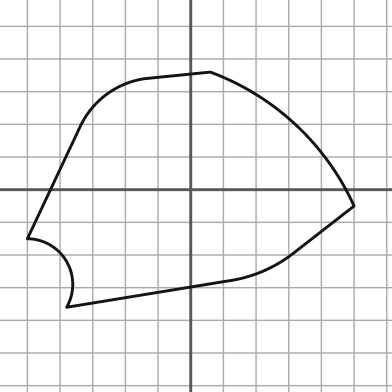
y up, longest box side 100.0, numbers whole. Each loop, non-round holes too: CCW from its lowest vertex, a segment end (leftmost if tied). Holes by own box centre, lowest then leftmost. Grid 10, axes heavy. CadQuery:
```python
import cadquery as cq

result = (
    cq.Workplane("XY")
    .moveTo(-38.0, -36.0)
    .lineTo(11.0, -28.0)
    .threePointArc((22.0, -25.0), (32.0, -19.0))
    .lineTo(50.0, -5.0)
    .threePointArc((32.0, 20.0), (6.0, 36.0))
    .lineTo(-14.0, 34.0)
    .threePointArc((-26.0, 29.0), (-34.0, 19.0))
    .lineTo(-50.0, -15.0)
    .threePointArc((-38.0, -22.0), (-38.0, -36.0))
    .close()
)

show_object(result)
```